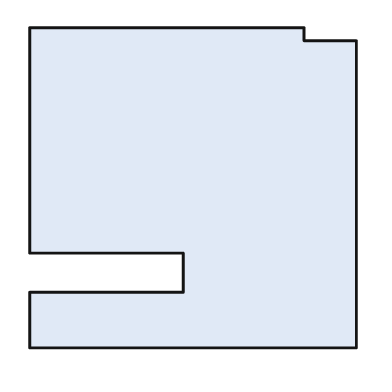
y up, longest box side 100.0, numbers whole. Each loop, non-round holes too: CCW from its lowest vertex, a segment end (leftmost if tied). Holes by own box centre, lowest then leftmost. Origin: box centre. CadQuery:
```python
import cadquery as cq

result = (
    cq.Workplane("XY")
    .moveTo(-50.0, -49.0)
    .lineTo(50.0, -49.0)
    .lineTo(50.0, 45.0)
    .lineTo(34.0, 45.0)
    .lineTo(34.0, 49.0)
    .lineTo(-50.0, 49.0)
    .lineTo(-50.0, -20.0)
    .lineTo(-3.0, -20.0)
    .lineTo(-3.0, -32.0)
    .lineTo(-50.0, -32.0)
    .close()
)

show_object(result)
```